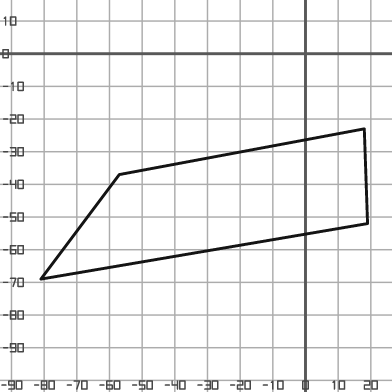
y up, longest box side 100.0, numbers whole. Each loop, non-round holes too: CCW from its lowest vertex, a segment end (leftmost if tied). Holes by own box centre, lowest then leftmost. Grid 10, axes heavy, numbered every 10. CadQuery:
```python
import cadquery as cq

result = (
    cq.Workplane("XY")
    .moveTo(-81.0, -69.0)
    .lineTo(19.0, -52.0)
    .lineTo(18.0, -23.0)
    .lineTo(-57.0, -37.0)
    .close()
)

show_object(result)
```